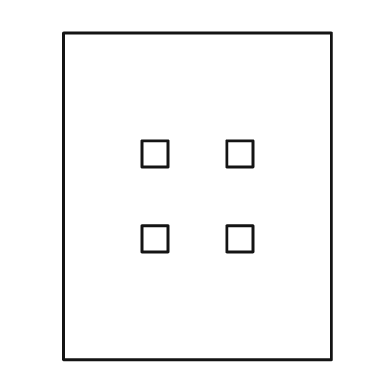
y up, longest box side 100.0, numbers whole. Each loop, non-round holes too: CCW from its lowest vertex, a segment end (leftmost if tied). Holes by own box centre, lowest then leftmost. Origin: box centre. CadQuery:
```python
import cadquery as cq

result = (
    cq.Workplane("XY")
    .moveTo(-41.0, -50.0)
    .lineTo(41.0, -50.0)
    .lineTo(41.0, 50.0)
    .lineTo(-41.0, 50.0)
    .close()
    .moveTo(-17.0, -17.0)
    .lineTo(-9.0, -17.0)
    .lineTo(-9.0, -9.0)
    .lineTo(-17.0, -9.0)
    .close()
    .moveTo(9.0, -17.0)
    .lineTo(17.0, -17.0)
    .lineTo(17.0, -9.0)
    .lineTo(9.0, -9.0)
    .close()
    .moveTo(-17.0, 9.0)
    .lineTo(-9.0, 9.0)
    .lineTo(-9.0, 17.0)
    .lineTo(-17.0, 17.0)
    .close()
    .moveTo(9.0, 9.0)
    .lineTo(17.0, 9.0)
    .lineTo(17.0, 17.0)
    .lineTo(9.0, 17.0)
    .close()
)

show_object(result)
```